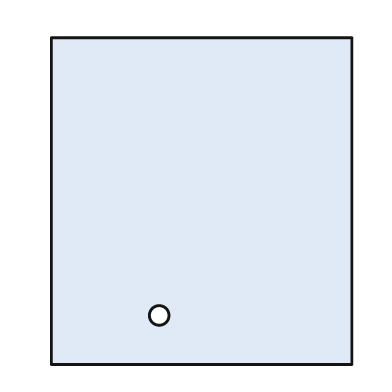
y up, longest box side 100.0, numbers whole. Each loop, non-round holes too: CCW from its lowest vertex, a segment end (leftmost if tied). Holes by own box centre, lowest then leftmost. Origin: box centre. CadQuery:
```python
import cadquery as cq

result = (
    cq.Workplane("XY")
    .moveTo(-46.0, -50.0)
    .lineTo(46.0, -50.0)
    .lineTo(46.0, 50.0)
    .lineTo(-46.0, 50.0)
    .close()
    .moveTo(-13.0, -35.0)
    .circle(3.0)
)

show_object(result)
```